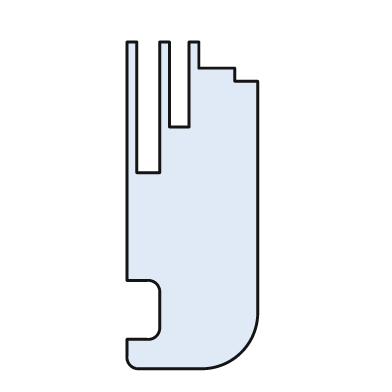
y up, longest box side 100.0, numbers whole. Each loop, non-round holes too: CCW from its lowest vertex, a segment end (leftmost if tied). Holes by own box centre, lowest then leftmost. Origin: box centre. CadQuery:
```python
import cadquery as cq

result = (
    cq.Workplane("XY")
    .moveTo(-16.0, -50.0)
    .lineTo(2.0, -50.0)
    .threePointArc((15.0, -45.0), (20.0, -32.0))
    .lineTo(20.0, 38.0)
    .lineTo(13.0, 38.0)
    .lineTo(13.0, 42.0)
    .lineTo(2.0, 42.0)
    .lineTo(2.0, 50.0)
    .lineTo(-1.0, 50.0)
    .lineTo(-1.0, 24.0)
    .lineTo(-7.0, 24.0)
    .lineTo(-7.0, 50.0)
    .lineTo(-10.0, 50.0)
    .lineTo(-10.0, 10.0)
    .lineTo(-17.0, 10.0)
    .lineTo(-17.0, 50.0)
    .lineTo(-20.0, 50.0)
    .lineTo(-20.0, -23.0)
    .lineTo(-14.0, -23.0)
    .threePointArc((-11.0, -24.0), (-10.0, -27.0))
    .lineTo(-10.0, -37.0)
    .threePointArc((-11.0, -40.0), (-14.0, -41.0))
    .lineTo(-20.0, -41.0)
    .lineTo(-20.0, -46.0)
    .threePointArc((-19.0, -49.0), (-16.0, -50.0))
    .close()
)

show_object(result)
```